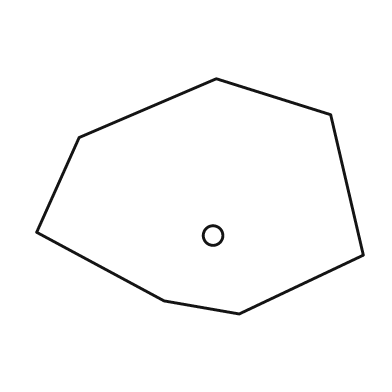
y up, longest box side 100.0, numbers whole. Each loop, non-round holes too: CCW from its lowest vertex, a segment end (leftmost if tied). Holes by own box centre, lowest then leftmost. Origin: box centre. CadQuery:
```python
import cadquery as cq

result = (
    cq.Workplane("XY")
    .moveTo(12.0, -36.0)
    .lineTo(50.0, -18.0)
    .lineTo(40.0, 25.0)
    .lineTo(5.0, 36.0)
    .lineTo(-37.0, 18.0)
    .lineTo(-50.0, -11.0)
    .lineTo(-11.0, -32.0)
    .close()
    .moveTo(4.0, -12.0)
    .circle(3.0)
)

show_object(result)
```